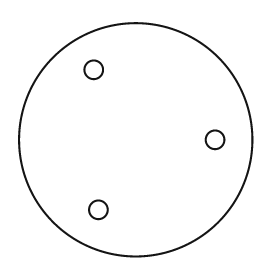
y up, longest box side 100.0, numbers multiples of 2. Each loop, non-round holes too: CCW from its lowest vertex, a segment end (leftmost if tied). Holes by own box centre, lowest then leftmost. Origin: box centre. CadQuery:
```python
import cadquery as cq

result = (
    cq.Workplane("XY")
    .moveTo(0.0, 0.0)
    .circle(50.0)
    .moveTo(-16.0, -30.0)
    .circle(4.0)
    .moveTo(34.0, 0.0)
    .circle(4.0)
    .moveTo(-18.0, 30.0)
    .circle(4.0)
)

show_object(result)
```